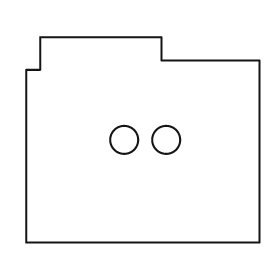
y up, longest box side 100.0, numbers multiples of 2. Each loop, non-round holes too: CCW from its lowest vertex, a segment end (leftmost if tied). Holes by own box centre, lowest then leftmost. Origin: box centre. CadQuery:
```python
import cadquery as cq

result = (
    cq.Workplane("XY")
    .moveTo(-50.0, -44.0)
    .lineTo(50.0, -44.0)
    .lineTo(50.0, 34.0)
    .lineTo(8.0, 34.0)
    .lineTo(8.0, 44.0)
    .lineTo(-44.0, 44.0)
    .lineTo(-44.0, 30.0)
    .lineTo(-50.0, 30.0)
    .close()
    .moveTo(-8.0, 0.0)
    .circle(6.0)
    .moveTo(10.0, 0.0)
    .circle(6.0)
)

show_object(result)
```